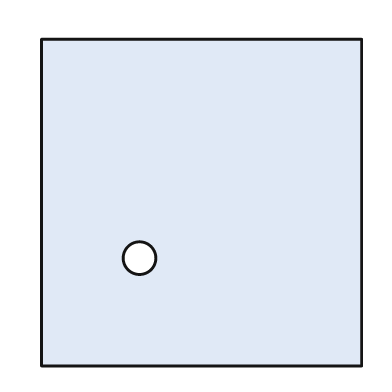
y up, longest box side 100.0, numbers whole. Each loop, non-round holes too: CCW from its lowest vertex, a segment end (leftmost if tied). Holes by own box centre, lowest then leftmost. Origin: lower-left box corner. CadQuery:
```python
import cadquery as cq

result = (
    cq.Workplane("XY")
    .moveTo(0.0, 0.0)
    .lineTo(98.0, 0.0)
    .lineTo(98.0, 100.0)
    .lineTo(0.0, 100.0)
    .close()
    .moveTo(30.0, 33.0)
    .circle(5.0)
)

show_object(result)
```